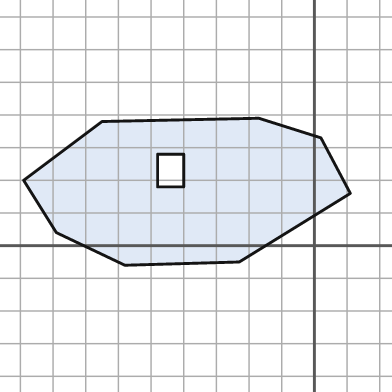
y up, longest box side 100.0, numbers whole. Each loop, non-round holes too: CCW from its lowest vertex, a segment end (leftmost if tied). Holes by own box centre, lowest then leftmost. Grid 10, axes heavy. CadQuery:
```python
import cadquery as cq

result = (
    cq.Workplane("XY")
    .moveTo(-58.0, -6.0)
    .lineTo(-23.0, -5.0)
    .lineTo(11.0, 16.0)
    .lineTo(2.0, 33.0)
    .lineTo(-17.0, 39.0)
    .lineTo(-65.0, 38.0)
    .lineTo(-89.0, 20.0)
    .lineTo(-79.0, 4.0)
    .close()
    .moveTo(-48.0, 18.0)
    .lineTo(-40.0, 18.0)
    .lineTo(-40.0, 28.0)
    .lineTo(-48.0, 28.0)
    .close()
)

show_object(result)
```